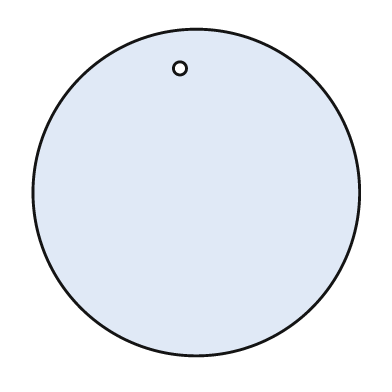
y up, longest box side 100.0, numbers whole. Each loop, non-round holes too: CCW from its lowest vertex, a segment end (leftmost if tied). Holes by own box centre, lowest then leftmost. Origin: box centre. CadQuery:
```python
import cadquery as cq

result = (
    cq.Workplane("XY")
    .moveTo(0.0, 0.0)
    .circle(50.0)
    .moveTo(-5.0, 38.0)
    .circle(2.0)
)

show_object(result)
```